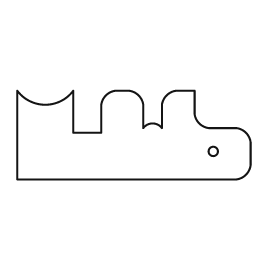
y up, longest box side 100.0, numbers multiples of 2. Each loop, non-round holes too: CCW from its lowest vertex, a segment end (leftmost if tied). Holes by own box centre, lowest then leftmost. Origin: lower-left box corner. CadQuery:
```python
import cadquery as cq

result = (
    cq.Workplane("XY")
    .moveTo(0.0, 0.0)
    .lineTo(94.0, 0.0)
    .threePointArc((98.0, 2.0), (100.0, 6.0))
    .lineTo(100.0, 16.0)
    .threePointArc((98.0, 20.0), (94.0, 22.0))
    .lineTo(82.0, 22.0)
    .threePointArc((78.0, 24.0), (76.0, 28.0))
    .lineTo(76.0, 38.0)
    .lineTo(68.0, 38.0)
    .threePointArc((64.0, 36.0), (62.0, 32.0))
    .lineTo(62.0, 22.0)
    .threePointArc((58.0, 24.0), (54.0, 22.0))
    .lineTo(54.0, 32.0)
    .threePointArc((52.0, 36.0), (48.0, 38.0))
    .lineTo(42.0, 38.0)
    .threePointArc((38.0, 36.0), (36.0, 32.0))
    .lineTo(36.0, 20.0)
    .lineTo(24.0, 20.0)
    .lineTo(24.0, 38.0)
    .threePointArc((12.0, 32.0), (0.0, 38.0))
    .close()
    .moveTo(84.0, 12.0)
    .circle(2.0)
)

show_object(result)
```